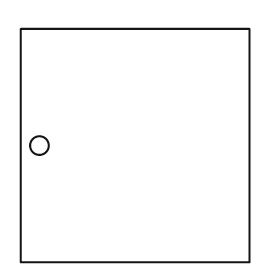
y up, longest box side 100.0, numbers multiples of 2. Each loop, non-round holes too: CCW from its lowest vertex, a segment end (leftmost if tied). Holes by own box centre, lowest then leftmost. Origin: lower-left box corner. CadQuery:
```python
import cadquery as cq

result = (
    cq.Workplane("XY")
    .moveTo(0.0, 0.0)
    .lineTo(98.0, 0.0)
    .lineTo(98.0, 100.0)
    .lineTo(0.0, 100.0)
    .close()
    .moveTo(8.0, 50.0)
    .circle(4.0)
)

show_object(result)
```